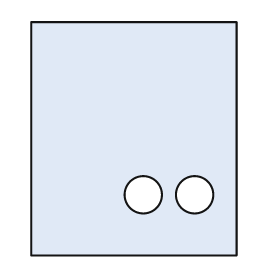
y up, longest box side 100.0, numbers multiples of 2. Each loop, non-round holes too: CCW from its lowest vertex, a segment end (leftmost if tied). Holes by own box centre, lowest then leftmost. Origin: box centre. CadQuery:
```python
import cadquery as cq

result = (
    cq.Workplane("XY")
    .moveTo(-44.0, -50.0)
    .lineTo(44.0, -50.0)
    .lineTo(44.0, 50.0)
    .lineTo(-44.0, 50.0)
    .close()
    .moveTo(4.0, -24.0)
    .circle(8.0)
    .moveTo(26.0, -24.0)
    .circle(8.0)
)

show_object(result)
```